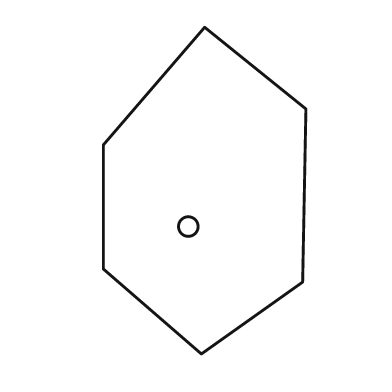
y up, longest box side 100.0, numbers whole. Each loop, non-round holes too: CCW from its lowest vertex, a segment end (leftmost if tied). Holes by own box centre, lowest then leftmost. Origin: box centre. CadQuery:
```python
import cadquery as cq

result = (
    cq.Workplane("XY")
    .moveTo(-1.0, -50.0)
    .lineTo(30.0, -28.0)
    .lineTo(31.0, 25.0)
    .lineTo(0.0, 50.0)
    .lineTo(-31.0, 14.0)
    .lineTo(-31.0, -24.0)
    .close()
    .moveTo(-5.0, -11.0)
    .circle(3.0)
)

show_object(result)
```